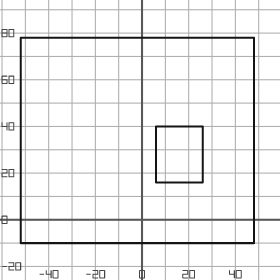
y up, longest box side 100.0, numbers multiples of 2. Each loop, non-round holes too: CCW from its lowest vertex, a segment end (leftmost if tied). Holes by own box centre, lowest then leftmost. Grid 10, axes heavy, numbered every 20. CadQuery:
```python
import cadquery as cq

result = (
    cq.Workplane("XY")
    .moveTo(-52.0, -10.0)
    .lineTo(48.0, -10.0)
    .lineTo(48.0, 78.0)
    .lineTo(-52.0, 78.0)
    .close()
    .moveTo(6.0, 16.0)
    .lineTo(26.0, 16.0)
    .lineTo(26.0, 40.0)
    .lineTo(6.0, 40.0)
    .close()
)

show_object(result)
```